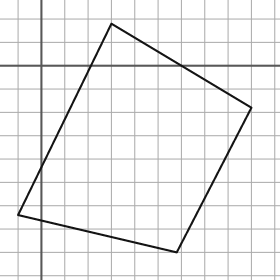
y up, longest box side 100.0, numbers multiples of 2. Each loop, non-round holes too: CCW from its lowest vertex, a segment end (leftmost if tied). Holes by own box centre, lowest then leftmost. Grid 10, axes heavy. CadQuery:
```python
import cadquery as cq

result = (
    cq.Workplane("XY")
    .moveTo(58.0, -80.0)
    .lineTo(90.0, -18.0)
    .lineTo(30.0, 18.0)
    .lineTo(-10.0, -64.0)
    .close()
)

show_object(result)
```